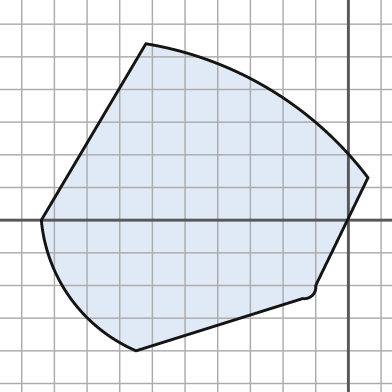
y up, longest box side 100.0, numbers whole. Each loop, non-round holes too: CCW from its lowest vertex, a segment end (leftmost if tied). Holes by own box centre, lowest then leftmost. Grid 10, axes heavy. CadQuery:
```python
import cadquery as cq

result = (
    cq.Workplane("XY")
    .moveTo(-65.0, -40.0)
    .lineTo(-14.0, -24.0)
    .threePointArc((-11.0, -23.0), (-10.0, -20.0))
    .lineTo(6.0, 13.0)
    .threePointArc((-24.0, 40.0), (-62.0, 54.0))
    .lineTo(-94.0, 0.0)
    .threePointArc((-85.0, -24.0), (-65.0, -40.0))
    .close()
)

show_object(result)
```